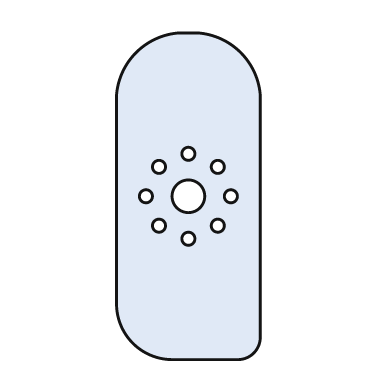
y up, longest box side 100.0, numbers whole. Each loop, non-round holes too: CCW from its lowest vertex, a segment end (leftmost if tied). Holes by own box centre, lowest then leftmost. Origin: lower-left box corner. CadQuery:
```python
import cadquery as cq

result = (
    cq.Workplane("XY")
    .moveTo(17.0, 0.0)
    .lineTo(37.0, 0.0)
    .threePointArc((42.0, 2.0), (44.0, 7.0))
    .lineTo(44.0, 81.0)
    .threePointArc((38.0, 94.0), (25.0, 100.0))
    .lineTo(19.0, 100.0)
    .threePointArc((6.0, 94.0), (0.0, 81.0))
    .lineTo(0.0, 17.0)
    .threePointArc((5.0, 5.0), (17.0, 0.0))
    .close()
    .moveTo(22.0, 37.0)
    .circle(2.0)
    .moveTo(13.0, 41.0)
    .circle(2.0)
    .moveTo(31.0, 41.0)
    .circle(2.0)
    .moveTo(9.0, 50.0)
    .circle(2.0)
    .moveTo(22.0, 50.0)
    .circle(5.0)
    .moveTo(35.0, 50.0)
    .circle(2.0)
    .moveTo(13.0, 59.0)
    .circle(2.0)
    .moveTo(31.0, 59.0)
    .circle(2.0)
    .moveTo(22.0, 63.0)
    .circle(2.0)
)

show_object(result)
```